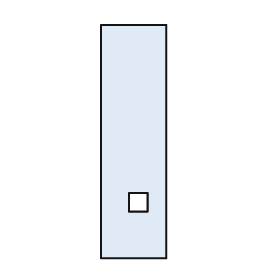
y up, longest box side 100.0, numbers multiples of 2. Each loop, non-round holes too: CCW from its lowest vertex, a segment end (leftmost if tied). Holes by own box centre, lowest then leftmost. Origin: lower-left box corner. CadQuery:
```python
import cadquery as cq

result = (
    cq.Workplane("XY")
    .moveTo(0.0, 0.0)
    .lineTo(28.0, 0.0)
    .lineTo(28.0, 100.0)
    .lineTo(0.0, 100.0)
    .close()
    .moveTo(12.0, 20.0)
    .lineTo(20.0, 20.0)
    .lineTo(20.0, 28.0)
    .lineTo(12.0, 28.0)
    .close()
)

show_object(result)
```